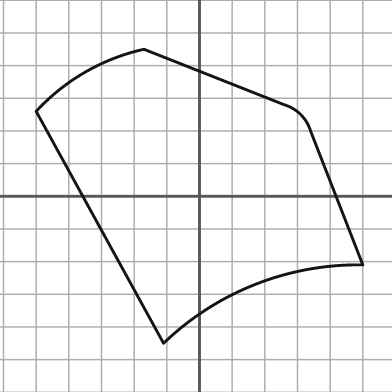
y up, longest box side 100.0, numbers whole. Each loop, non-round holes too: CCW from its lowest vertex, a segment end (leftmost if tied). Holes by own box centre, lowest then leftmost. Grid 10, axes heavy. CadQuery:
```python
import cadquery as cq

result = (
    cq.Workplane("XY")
    .moveTo(-11.0, -45.0)
    .threePointArc((17.0, -27.0), (50.0, -21.0))
    .lineTo(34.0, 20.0)
    .threePointArc((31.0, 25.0), (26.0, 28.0))
    .lineTo(-17.0, 45.0)
    .threePointArc((-35.0, 38.0), (-50.0, 26.0))
    .close()
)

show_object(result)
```